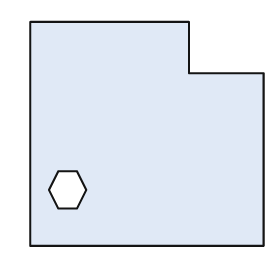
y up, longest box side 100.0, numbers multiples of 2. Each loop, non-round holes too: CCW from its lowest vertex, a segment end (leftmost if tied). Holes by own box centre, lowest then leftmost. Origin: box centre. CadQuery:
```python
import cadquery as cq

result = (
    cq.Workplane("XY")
    .moveTo(-50.0, -48.0)
    .lineTo(50.0, -48.0)
    .lineTo(50.0, 26.0)
    .lineTo(18.0, 26.0)
    .lineTo(18.0, 48.0)
    .lineTo(-50.0, 48.0)
    .close()
    .moveTo(-38.0, -32.0)
    .lineTo(-30.0, -32.0)
    .lineTo(-26.0, -24.0)
    .lineTo(-30.0, -16.0)
    .lineTo(-38.0, -16.0)
    .lineTo(-42.0, -24.0)
    .close()
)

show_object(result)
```